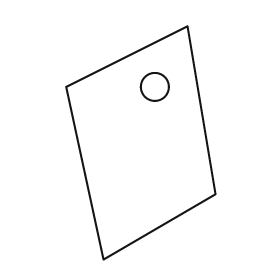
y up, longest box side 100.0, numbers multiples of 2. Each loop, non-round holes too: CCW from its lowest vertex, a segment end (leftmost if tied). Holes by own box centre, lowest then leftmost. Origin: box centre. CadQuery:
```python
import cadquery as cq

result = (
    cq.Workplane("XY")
    .moveTo(-16.0, -50.0)
    .lineTo(32.0, -22.0)
    .lineTo(20.0, 50.0)
    .lineTo(-32.0, 24.0)
    .close()
    .moveTo(6.0, 24.0)
    .circle(6.0)
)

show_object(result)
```